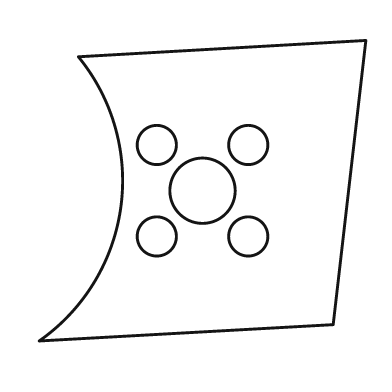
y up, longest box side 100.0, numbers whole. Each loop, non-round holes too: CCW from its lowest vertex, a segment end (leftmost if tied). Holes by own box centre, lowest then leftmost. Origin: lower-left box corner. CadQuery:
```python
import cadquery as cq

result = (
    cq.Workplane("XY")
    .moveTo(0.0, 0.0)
    .lineTo(90.0, 5.0)
    .lineTo(100.0, 92.0)
    .lineTo(12.0, 87.0)
    .threePointArc((25.0, 41.0), (0.0, 0.0))
    .close()
    .moveTo(36.0, 32.0)
    .circle(6.0)
    .moveTo(64.0, 32.0)
    .circle(6.0)
    .moveTo(50.0, 46.0)
    .circle(10.0)
    .moveTo(36.0, 60.0)
    .circle(6.0)
    .moveTo(64.0, 60.0)
    .circle(6.0)
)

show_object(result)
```